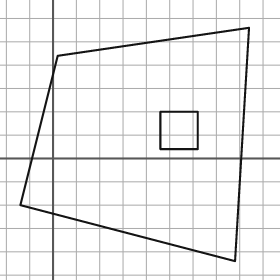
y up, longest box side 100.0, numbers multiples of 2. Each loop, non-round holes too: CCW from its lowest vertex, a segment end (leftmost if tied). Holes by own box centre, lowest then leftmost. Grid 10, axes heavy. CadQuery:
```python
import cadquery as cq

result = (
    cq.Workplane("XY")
    .moveTo(78.0, -44.0)
    .lineTo(84.0, 56.0)
    .lineTo(2.0, 44.0)
    .lineTo(-14.0, -20.0)
    .close()
    .moveTo(46.0, 4.0)
    .lineTo(62.0, 4.0)
    .lineTo(62.0, 20.0)
    .lineTo(46.0, 20.0)
    .close()
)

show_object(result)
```